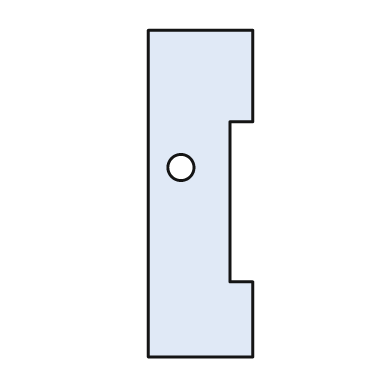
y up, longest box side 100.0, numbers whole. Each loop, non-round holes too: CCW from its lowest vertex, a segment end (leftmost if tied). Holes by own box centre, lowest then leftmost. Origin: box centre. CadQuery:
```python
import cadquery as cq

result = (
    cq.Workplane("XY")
    .moveTo(-16.0, -50.0)
    .lineTo(16.0, -50.0)
    .lineTo(16.0, -27.0)
    .lineTo(9.0, -27.0)
    .lineTo(9.0, 22.0)
    .lineTo(16.0, 22.0)
    .lineTo(16.0, 50.0)
    .lineTo(-16.0, 50.0)
    .close()
    .moveTo(-6.0, 8.0)
    .circle(4.0)
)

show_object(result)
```